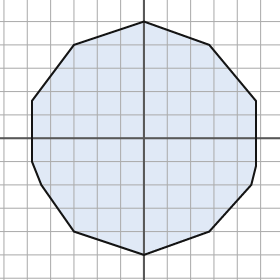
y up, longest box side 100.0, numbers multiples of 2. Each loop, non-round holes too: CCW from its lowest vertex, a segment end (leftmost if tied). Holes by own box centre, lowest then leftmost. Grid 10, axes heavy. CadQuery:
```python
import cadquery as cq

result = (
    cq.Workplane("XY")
    .moveTo(0.0, -50.0)
    .lineTo(28.0, -40.0)
    .lineTo(46.0, -20.0)
    .lineTo(48.0, -12.0)
    .lineTo(48.0, 16.0)
    .lineTo(28.0, 40.0)
    .lineTo(0.0, 50.0)
    .lineTo(-30.0, 40.0)
    .lineTo(-48.0, 16.0)
    .lineTo(-48.0, -10.0)
    .lineTo(-44.0, -20.0)
    .lineTo(-30.0, -40.0)
    .close()
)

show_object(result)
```